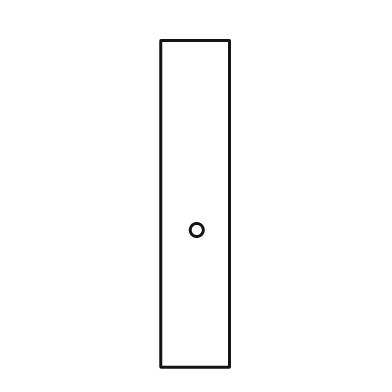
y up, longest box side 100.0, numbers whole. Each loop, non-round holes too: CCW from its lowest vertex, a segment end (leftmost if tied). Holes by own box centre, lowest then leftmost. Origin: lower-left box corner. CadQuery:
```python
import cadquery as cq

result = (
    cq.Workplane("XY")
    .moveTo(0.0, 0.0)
    .lineTo(21.0, 0.0)
    .lineTo(21.0, 100.0)
    .lineTo(0.0, 100.0)
    .close()
    .moveTo(11.0, 42.0)
    .circle(2.0)
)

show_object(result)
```